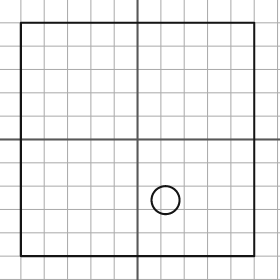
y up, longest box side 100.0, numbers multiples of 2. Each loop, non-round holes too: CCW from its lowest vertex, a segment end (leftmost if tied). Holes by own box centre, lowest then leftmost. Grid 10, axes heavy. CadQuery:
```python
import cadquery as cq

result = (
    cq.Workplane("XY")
    .moveTo(-50.0, -50.0)
    .lineTo(50.0, -50.0)
    .lineTo(50.0, 50.0)
    .lineTo(-50.0, 50.0)
    .close()
    .moveTo(12.0, -26.0)
    .circle(6.0)
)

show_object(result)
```